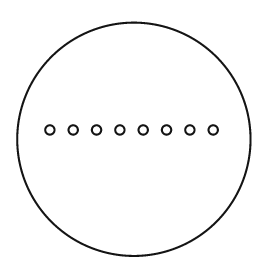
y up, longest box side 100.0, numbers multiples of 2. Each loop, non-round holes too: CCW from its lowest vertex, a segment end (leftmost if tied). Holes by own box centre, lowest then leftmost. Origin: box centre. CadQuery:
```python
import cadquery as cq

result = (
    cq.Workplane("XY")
    .moveTo(0.0, 0.0)
    .circle(50.0)
    .moveTo(-36.0, 4.0)
    .circle(2.0)
    .moveTo(-26.0, 4.0)
    .circle(2.0)
    .moveTo(-16.0, 4.0)
    .circle(2.0)
    .moveTo(-6.0, 4.0)
    .circle(2.0)
    .moveTo(4.0, 4.0)
    .circle(2.0)
    .moveTo(14.0, 4.0)
    .circle(2.0)
    .moveTo(24.0, 4.0)
    .circle(2.0)
    .moveTo(34.0, 4.0)
    .circle(2.0)
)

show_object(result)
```